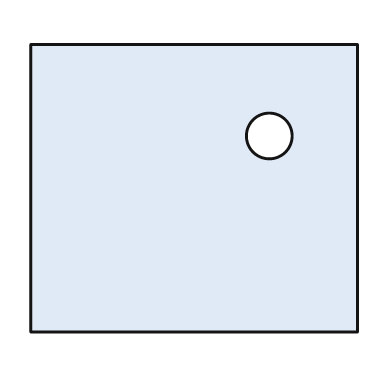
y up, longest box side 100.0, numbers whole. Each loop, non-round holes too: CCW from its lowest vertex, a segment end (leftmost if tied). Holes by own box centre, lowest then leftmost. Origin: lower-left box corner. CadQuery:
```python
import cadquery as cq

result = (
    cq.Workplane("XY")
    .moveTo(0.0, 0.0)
    .lineTo(100.0, 0.0)
    .lineTo(100.0, 88.0)
    .lineTo(0.0, 88.0)
    .close()
    .moveTo(73.0, 60.0)
    .circle(7.0)
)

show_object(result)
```